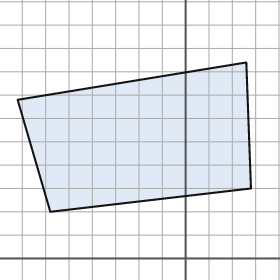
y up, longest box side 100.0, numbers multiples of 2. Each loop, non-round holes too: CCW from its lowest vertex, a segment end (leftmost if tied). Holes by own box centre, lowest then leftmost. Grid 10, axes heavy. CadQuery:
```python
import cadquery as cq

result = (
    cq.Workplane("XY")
    .moveTo(-58.0, 20.0)
    .lineTo(28.0, 30.0)
    .lineTo(26.0, 84.0)
    .lineTo(-72.0, 68.0)
    .close()
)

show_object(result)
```